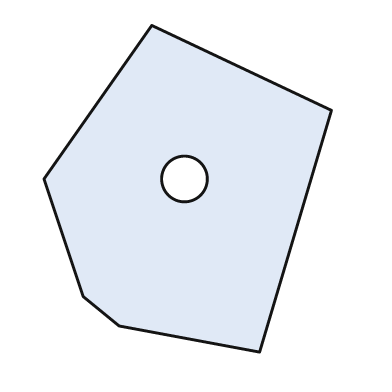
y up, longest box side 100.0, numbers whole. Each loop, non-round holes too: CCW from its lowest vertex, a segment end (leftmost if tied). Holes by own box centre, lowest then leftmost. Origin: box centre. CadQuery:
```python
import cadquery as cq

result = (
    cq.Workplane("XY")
    .moveTo(22.0, -50.0)
    .lineTo(44.0, 24.0)
    .lineTo(-11.0, 50.0)
    .lineTo(-44.0, 3.0)
    .lineTo(-32.0, -33.0)
    .lineTo(-21.0, -42.0)
    .close()
    .moveTo(-1.0, 3.0)
    .circle(7.0)
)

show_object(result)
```